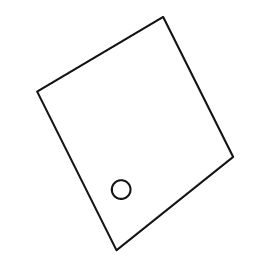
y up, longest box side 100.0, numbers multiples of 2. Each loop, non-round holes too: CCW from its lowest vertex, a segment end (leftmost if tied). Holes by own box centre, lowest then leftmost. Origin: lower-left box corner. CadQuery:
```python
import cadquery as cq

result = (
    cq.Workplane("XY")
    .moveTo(34.0, 0.0)
    .lineTo(84.0, 40.0)
    .lineTo(54.0, 100.0)
    .lineTo(0.0, 68.0)
    .close()
    .moveTo(36.0, 26.0)
    .circle(4.0)
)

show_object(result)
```